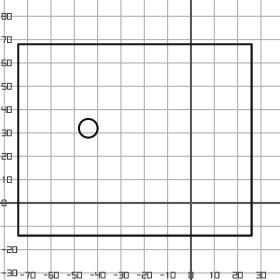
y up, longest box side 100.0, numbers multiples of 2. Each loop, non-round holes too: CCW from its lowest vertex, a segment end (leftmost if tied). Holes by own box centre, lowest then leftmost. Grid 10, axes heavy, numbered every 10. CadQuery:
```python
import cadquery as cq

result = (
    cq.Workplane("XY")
    .moveTo(-74.0, -14.0)
    .lineTo(26.0, -14.0)
    .lineTo(26.0, 68.0)
    .lineTo(-74.0, 68.0)
    .close()
    .moveTo(-44.0, 32.0)
    .circle(4.0)
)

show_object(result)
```